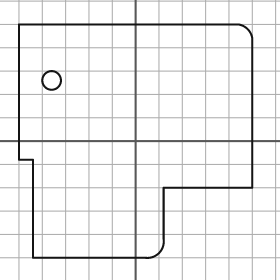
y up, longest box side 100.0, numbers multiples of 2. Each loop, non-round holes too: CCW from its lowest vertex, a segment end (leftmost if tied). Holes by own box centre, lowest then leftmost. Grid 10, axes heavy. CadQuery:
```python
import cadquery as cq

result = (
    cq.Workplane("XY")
    .moveTo(-44.0, -50.0)
    .lineTo(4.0, -50.0)
    .threePointArc((10.0, -48.0), (12.0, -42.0))
    .lineTo(12.0, -20.0)
    .lineTo(50.0, -20.0)
    .lineTo(50.0, 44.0)
    .threePointArc((48.0, 48.0), (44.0, 50.0))
    .lineTo(-50.0, 50.0)
    .lineTo(-50.0, -8.0)
    .lineTo(-44.0, -8.0)
    .close()
    .moveTo(-36.0, 26.0)
    .circle(4.0)
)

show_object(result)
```